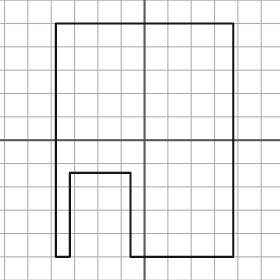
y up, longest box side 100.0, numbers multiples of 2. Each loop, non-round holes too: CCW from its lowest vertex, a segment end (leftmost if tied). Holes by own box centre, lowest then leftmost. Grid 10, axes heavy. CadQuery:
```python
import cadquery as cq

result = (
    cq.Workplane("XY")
    .moveTo(-38.0, -50.0)
    .lineTo(-32.0, -50.0)
    .lineTo(-32.0, -14.0)
    .lineTo(-6.0, -14.0)
    .lineTo(-6.0, -50.0)
    .lineTo(38.0, -50.0)
    .lineTo(38.0, 50.0)
    .lineTo(-38.0, 50.0)
    .close()
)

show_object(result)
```